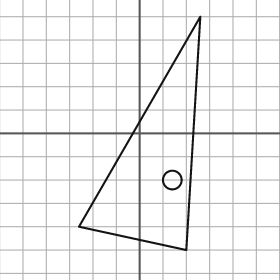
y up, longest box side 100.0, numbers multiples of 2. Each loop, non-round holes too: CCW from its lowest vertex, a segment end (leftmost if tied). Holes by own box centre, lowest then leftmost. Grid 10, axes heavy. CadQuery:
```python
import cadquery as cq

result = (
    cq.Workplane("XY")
    .moveTo(20.0, -50.0)
    .lineTo(26.0, 50.0)
    .lineTo(-26.0, -40.0)
    .close()
    .moveTo(14.0, -20.0)
    .circle(4.0)
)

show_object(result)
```